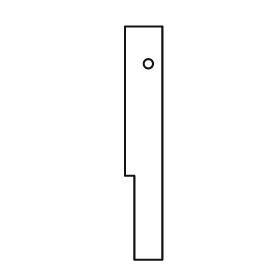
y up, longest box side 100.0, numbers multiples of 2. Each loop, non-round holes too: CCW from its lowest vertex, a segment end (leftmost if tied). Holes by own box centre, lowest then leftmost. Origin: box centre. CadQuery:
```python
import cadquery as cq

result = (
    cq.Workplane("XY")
    .moveTo(-4.0, -50.0)
    .lineTo(8.0, -50.0)
    .lineTo(8.0, 50.0)
    .lineTo(-8.0, 50.0)
    .lineTo(-8.0, -14.0)
    .lineTo(-4.0, -14.0)
    .close()
    .moveTo(2.0, 34.0)
    .circle(2.0)
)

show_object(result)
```